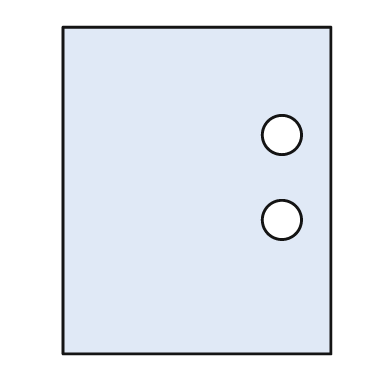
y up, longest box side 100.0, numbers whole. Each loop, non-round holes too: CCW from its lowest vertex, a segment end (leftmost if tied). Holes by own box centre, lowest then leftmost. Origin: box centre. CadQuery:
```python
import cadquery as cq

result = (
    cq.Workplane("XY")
    .moveTo(-41.0, -50.0)
    .lineTo(41.0, -50.0)
    .lineTo(41.0, 50.0)
    .lineTo(-41.0, 50.0)
    .close()
    .moveTo(26.0, -9.0)
    .circle(6.0)
    .moveTo(26.0, 17.0)
    .circle(6.0)
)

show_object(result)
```